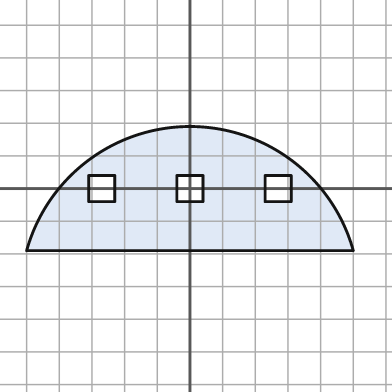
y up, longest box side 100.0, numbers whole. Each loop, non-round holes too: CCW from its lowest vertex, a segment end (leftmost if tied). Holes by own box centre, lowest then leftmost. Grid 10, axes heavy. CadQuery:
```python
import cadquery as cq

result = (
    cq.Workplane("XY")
    .moveTo(-50.0, -19.0)
    .lineTo(50.0, -19.0)
    .threePointArc((0.0, 19.0), (-50.0, -19.0))
    .close()
    .moveTo(-31.0, -4.0)
    .lineTo(-23.0, -4.0)
    .lineTo(-23.0, 4.0)
    .lineTo(-31.0, 4.0)
    .close()
    .moveTo(-4.0, -4.0)
    .lineTo(4.0, -4.0)
    .lineTo(4.0, 4.0)
    .lineTo(-4.0, 4.0)
    .close()
    .moveTo(23.0, -4.0)
    .lineTo(31.0, -4.0)
    .lineTo(31.0, 4.0)
    .lineTo(23.0, 4.0)
    .close()
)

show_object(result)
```